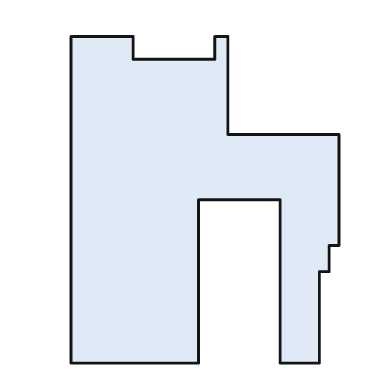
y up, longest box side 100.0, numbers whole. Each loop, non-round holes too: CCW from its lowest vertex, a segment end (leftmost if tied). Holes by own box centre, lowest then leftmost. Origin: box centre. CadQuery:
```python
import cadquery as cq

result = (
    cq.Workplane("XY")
    .moveTo(-41.0, -50.0)
    .lineTo(-2.0, -50.0)
    .lineTo(-2.0, 0.0)
    .lineTo(23.0, 0.0)
    .lineTo(23.0, -50.0)
    .lineTo(35.0, -50.0)
    .lineTo(35.0, -22.0)
    .lineTo(38.0, -22.0)
    .lineTo(38.0, -14.0)
    .lineTo(41.0, -14.0)
    .lineTo(41.0, 20.0)
    .lineTo(7.0, 20.0)
    .lineTo(7.0, 50.0)
    .lineTo(3.0, 50.0)
    .lineTo(3.0, 43.0)
    .lineTo(-22.0, 43.0)
    .lineTo(-22.0, 50.0)
    .lineTo(-41.0, 50.0)
    .close()
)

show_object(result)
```